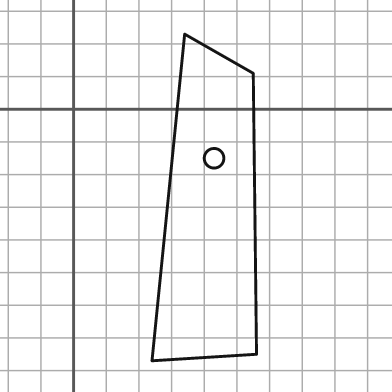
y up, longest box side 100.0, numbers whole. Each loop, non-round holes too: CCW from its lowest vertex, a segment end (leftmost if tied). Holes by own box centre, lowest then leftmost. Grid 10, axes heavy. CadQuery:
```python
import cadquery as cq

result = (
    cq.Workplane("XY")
    .moveTo(24.0, -77.0)
    .lineTo(56.0, -75.0)
    .lineTo(55.0, 11.0)
    .lineTo(34.0, 23.0)
    .close()
    .moveTo(43.0, -15.0)
    .circle(3.0)
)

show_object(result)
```